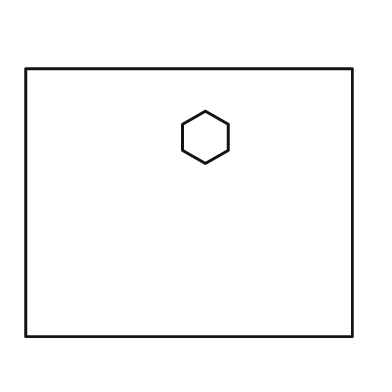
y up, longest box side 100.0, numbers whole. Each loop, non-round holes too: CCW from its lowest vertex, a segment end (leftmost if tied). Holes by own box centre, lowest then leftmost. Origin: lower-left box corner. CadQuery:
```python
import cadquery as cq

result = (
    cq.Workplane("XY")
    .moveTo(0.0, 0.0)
    .lineTo(100.0, 0.0)
    .lineTo(100.0, 82.0)
    .lineTo(0.0, 82.0)
    .close()
    .moveTo(55.0, 53.0)
    .lineTo(62.0, 57.0)
    .lineTo(62.0, 65.0)
    .lineTo(55.0, 69.0)
    .lineTo(48.0, 65.0)
    .lineTo(48.0, 57.0)
    .close()
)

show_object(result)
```